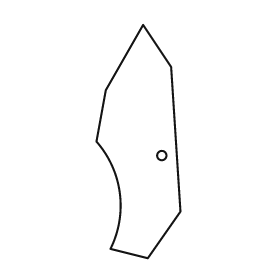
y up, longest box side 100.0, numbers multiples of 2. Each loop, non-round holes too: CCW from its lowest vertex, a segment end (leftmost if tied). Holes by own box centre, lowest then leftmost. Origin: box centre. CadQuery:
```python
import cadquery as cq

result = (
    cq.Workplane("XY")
    .moveTo(4.0, -50.0)
    .lineTo(18.0, -30.0)
    .lineTo(14.0, 32.0)
    .lineTo(2.0, 50.0)
    .lineTo(-14.0, 22.0)
    .lineTo(-18.0, 0.0)
    .threePointArc((-8.0, -22.0), (-12.0, -46.0))
    .close()
    .moveTo(10.0, -6.0)
    .circle(2.0)
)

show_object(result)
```